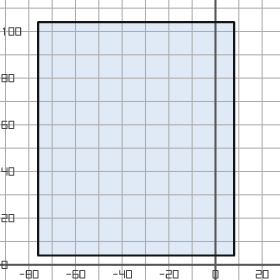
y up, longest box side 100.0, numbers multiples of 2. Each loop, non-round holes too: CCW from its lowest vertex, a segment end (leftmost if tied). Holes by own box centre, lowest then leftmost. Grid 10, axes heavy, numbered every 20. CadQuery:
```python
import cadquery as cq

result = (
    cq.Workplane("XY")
    .moveTo(-76.0, 4.0)
    .lineTo(8.0, 4.0)
    .lineTo(8.0, 104.0)
    .lineTo(-76.0, 104.0)
    .close()
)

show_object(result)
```